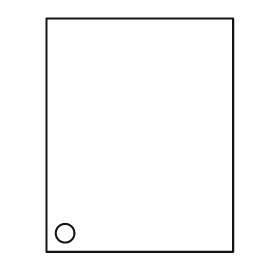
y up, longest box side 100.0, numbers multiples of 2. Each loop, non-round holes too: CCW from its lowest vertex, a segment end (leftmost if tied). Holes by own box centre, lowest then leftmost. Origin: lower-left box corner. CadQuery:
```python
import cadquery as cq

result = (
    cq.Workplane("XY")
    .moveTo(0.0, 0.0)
    .lineTo(80.0, 0.0)
    .lineTo(80.0, 100.0)
    .lineTo(0.0, 100.0)
    .close()
    .moveTo(8.0, 8.0)
    .circle(4.0)
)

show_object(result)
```